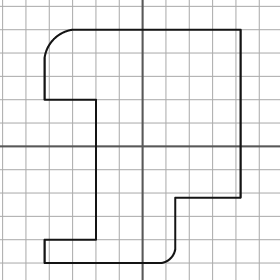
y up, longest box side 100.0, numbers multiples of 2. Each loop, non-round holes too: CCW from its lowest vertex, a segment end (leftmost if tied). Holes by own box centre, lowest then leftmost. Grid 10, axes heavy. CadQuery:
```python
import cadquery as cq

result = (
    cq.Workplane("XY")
    .moveTo(-42.0, -50.0)
    .lineTo(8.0, -50.0)
    .threePointArc((12.0, -48.0), (14.0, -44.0))
    .lineTo(14.0, -22.0)
    .lineTo(42.0, -22.0)
    .lineTo(42.0, 50.0)
    .lineTo(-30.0, 50.0)
    .threePointArc((-38.0, 46.0), (-42.0, 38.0))
    .lineTo(-42.0, 20.0)
    .lineTo(-20.0, 20.0)
    .lineTo(-20.0, -40.0)
    .lineTo(-42.0, -40.0)
    .close()
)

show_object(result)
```